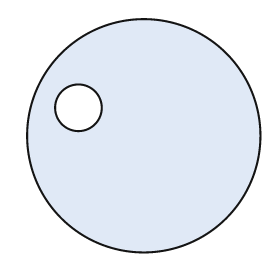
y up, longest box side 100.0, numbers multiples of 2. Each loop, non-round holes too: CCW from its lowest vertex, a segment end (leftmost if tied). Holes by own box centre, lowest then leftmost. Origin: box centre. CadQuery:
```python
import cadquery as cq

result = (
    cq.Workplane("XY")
    .moveTo(0.0, 0.0)
    .circle(50.0)
    .moveTo(-28.0, 12.0)
    .circle(10.0)
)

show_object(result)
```